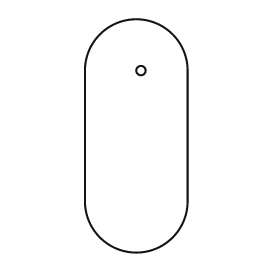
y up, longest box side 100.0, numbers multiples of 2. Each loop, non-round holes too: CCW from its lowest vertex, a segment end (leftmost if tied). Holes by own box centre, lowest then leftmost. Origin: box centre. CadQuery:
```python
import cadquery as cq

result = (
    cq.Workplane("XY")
    .moveTo(-22.0, -28.0)
    .threePointArc((0.0, -50.0), (22.0, -28.0))
    .lineTo(22.0, 28.0)
    .threePointArc((0.0, 50.0), (-22.0, 28.0))
    .close()
    .moveTo(2.0, 28.0)
    .circle(2.0)
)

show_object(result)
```